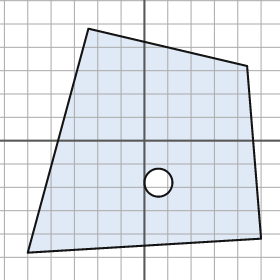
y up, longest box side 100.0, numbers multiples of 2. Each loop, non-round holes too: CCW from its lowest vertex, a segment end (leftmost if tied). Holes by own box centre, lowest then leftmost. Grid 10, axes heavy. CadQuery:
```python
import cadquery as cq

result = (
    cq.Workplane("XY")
    .moveTo(-50.0, -48.0)
    .lineTo(50.0, -42.0)
    .lineTo(44.0, 32.0)
    .lineTo(-24.0, 48.0)
    .close()
    .moveTo(6.0, -18.0)
    .circle(6.0)
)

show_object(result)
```